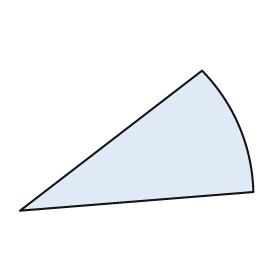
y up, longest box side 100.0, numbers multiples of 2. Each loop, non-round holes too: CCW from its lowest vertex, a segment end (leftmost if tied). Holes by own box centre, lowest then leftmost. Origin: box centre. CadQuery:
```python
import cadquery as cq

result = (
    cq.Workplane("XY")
    .moveTo(-50.0, -30.0)
    .lineTo(50.0, -22.0)
    .threePointArc((44.0, 6.0), (28.0, 30.0))
    .close()
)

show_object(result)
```